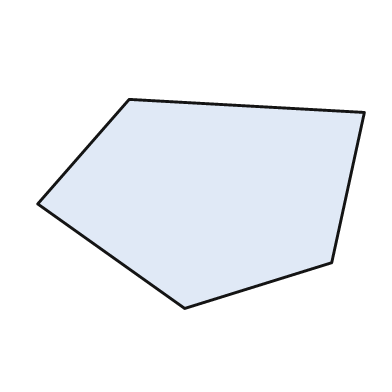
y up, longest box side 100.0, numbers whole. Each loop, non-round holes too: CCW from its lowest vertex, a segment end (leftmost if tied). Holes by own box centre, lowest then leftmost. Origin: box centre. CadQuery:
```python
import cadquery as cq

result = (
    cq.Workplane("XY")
    .moveTo(-5.0, -32.0)
    .lineTo(40.0, -18.0)
    .lineTo(50.0, 28.0)
    .lineTo(-22.0, 32.0)
    .lineTo(-50.0, 0.0)
    .close()
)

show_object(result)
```